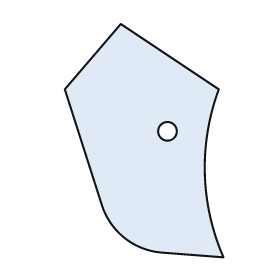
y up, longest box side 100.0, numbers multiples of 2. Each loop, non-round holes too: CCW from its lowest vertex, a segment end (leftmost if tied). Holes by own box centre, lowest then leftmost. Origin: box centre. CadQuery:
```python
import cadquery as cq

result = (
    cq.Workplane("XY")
    .moveTo(34.0, -50.0)
    .threePointArc((26.0, -14.0), (32.0, 22.0))
    .lineTo(-10.0, 50.0)
    .lineTo(-34.0, 22.0)
    .lineTo(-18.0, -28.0)
    .threePointArc((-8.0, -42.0), (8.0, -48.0))
    .close()
    .moveTo(10.0, 4.0)
    .circle(4.0)
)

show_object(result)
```